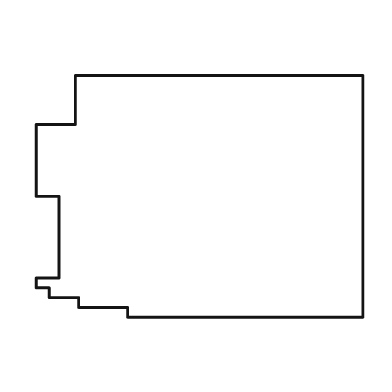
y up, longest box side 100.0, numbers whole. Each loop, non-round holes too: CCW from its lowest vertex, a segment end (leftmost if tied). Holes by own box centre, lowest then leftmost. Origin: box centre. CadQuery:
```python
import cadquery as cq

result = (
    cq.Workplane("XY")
    .moveTo(-22.0, -37.0)
    .lineTo(50.0, -37.0)
    .lineTo(50.0, 37.0)
    .lineTo(-38.0, 37.0)
    .lineTo(-38.0, 22.0)
    .lineTo(-50.0, 22.0)
    .lineTo(-50.0, 0.0)
    .lineTo(-43.0, 0.0)
    .lineTo(-43.0, -25.0)
    .lineTo(-50.0, -25.0)
    .lineTo(-50.0, -28.0)
    .lineTo(-46.0, -28.0)
    .lineTo(-46.0, -31.0)
    .lineTo(-37.0, -31.0)
    .lineTo(-37.0, -34.0)
    .lineTo(-22.0, -34.0)
    .close()
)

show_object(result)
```